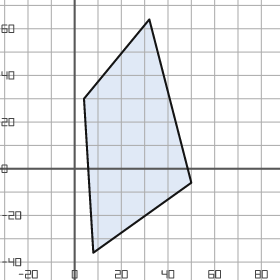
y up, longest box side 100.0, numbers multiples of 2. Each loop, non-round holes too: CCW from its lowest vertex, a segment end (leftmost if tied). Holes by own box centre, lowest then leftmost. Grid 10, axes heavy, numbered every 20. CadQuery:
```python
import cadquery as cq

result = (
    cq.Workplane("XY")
    .moveTo(8.0, -36.0)
    .lineTo(50.0, -6.0)
    .lineTo(32.0, 64.0)
    .lineTo(4.0, 30.0)
    .close()
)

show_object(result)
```